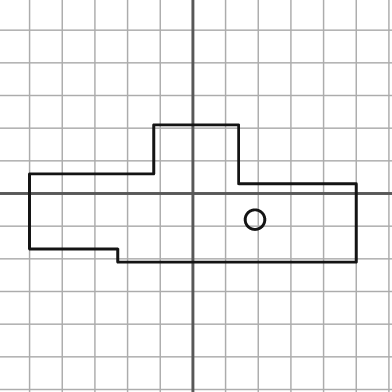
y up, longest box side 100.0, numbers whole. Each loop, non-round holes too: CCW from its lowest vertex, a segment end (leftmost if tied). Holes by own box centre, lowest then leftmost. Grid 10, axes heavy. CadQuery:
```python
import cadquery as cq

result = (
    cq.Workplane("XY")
    .moveTo(-23.0, -21.0)
    .lineTo(50.0, -21.0)
    .lineTo(50.0, 3.0)
    .lineTo(14.0, 3.0)
    .lineTo(14.0, 21.0)
    .lineTo(-12.0, 21.0)
    .lineTo(-12.0, 6.0)
    .lineTo(-50.0, 6.0)
    .lineTo(-50.0, -17.0)
    .lineTo(-23.0, -17.0)
    .close()
    .moveTo(19.0, -8.0)
    .circle(3.0)
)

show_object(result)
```